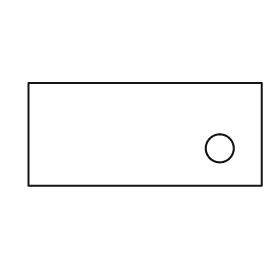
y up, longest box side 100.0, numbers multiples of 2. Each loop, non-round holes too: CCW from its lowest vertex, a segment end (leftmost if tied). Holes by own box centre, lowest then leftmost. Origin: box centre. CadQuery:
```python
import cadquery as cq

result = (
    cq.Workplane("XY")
    .moveTo(-50.0, -22.0)
    .lineTo(50.0, -22.0)
    .lineTo(50.0, 22.0)
    .lineTo(-50.0, 22.0)
    .close()
    .moveTo(32.0, -6.0)
    .circle(6.0)
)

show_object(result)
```